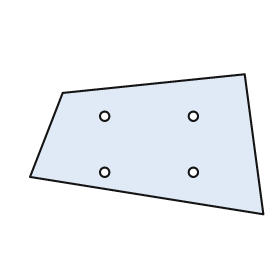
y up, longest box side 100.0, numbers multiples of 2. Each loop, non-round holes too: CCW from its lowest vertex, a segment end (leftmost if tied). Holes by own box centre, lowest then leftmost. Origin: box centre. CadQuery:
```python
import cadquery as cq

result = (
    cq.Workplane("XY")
    .moveTo(50.0, -30.0)
    .lineTo(42.0, 30.0)
    .lineTo(-36.0, 22.0)
    .lineTo(-50.0, -14.0)
    .close()
    .moveTo(-18.0, -12.0)
    .circle(2.0)
    .moveTo(20.0, -12.0)
    .circle(2.0)
    .moveTo(-18.0, 12.0)
    .circle(2.0)
    .moveTo(20.0, 12.0)
    .circle(2.0)
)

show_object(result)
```